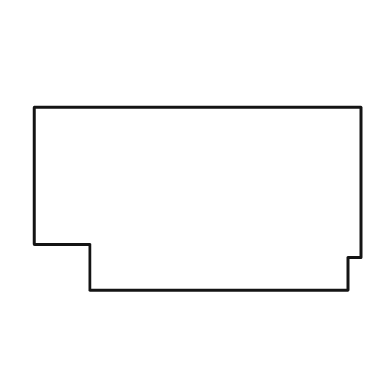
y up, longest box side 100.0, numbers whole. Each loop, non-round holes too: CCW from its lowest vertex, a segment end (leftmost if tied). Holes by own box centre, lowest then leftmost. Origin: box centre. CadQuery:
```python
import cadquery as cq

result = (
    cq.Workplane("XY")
    .moveTo(-33.0, -28.0)
    .lineTo(46.0, -28.0)
    .lineTo(46.0, -18.0)
    .lineTo(50.0, -18.0)
    .lineTo(50.0, 28.0)
    .lineTo(-50.0, 28.0)
    .lineTo(-50.0, -14.0)
    .lineTo(-33.0, -14.0)
    .close()
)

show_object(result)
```